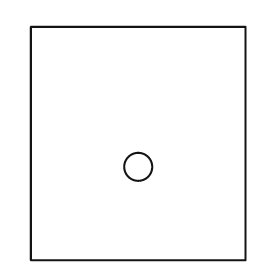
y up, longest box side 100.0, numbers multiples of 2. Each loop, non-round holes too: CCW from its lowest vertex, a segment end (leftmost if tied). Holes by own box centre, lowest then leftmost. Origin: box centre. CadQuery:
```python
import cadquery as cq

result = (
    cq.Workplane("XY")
    .moveTo(-46.0, -50.0)
    .lineTo(46.0, -50.0)
    .lineTo(46.0, 50.0)
    .lineTo(-46.0, 50.0)
    .close()
    .moveTo(0.0, -10.0)
    .circle(6.0)
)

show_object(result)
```